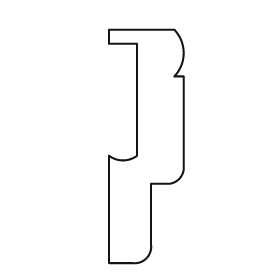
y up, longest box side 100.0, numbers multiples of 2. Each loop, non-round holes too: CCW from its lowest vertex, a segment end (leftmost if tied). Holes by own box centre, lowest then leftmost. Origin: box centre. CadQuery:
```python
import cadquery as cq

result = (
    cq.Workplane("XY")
    .moveTo(-16.0, -50.0)
    .lineTo(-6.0, -50.0)
    .threePointArc((0.0, -48.0), (2.0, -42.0))
    .lineTo(2.0, -16.0)
    .lineTo(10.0, -16.0)
    .threePointArc((14.0, -14.0), (16.0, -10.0))
    .lineTo(16.0, 30.0)
    .lineTo(12.0, 30.0)
    .threePointArc((16.0, 40.0), (12.0, 50.0))
    .lineTo(-16.0, 50.0)
    .lineTo(-16.0, 44.0)
    .lineTo(-4.0, 44.0)
    .lineTo(-4.0, -4.0)
    .threePointArc((-10.0, -6.0), (-16.0, -4.0))
    .close()
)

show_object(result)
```